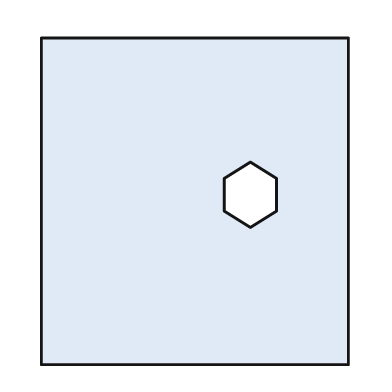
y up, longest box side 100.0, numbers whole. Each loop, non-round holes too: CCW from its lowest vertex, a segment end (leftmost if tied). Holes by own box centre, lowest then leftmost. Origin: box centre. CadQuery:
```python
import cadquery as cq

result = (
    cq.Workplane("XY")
    .moveTo(-47.0, -50.0)
    .lineTo(47.0, -50.0)
    .lineTo(47.0, 50.0)
    .lineTo(-47.0, 50.0)
    .close()
    .moveTo(17.0, -8.0)
    .lineTo(25.0, -3.0)
    .lineTo(25.0, 7.0)
    .lineTo(17.0, 12.0)
    .lineTo(9.0, 7.0)
    .lineTo(9.0, -3.0)
    .close()
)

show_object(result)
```